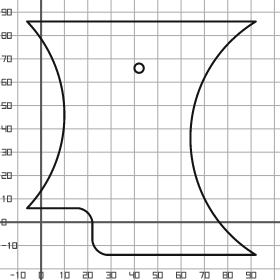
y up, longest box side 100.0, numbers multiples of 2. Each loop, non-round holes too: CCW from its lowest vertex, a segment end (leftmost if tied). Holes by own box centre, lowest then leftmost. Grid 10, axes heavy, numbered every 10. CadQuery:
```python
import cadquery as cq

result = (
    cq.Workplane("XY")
    .moveTo(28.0, -14.0)
    .lineTo(92.0, -14.0)
    .threePointArc((64.0, 36.0), (92.0, 86.0))
    .lineTo(-6.0, 86.0)
    .threePointArc((10.0, 46.0), (-6.0, 6.0))
    .lineTo(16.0, 6.0)
    .threePointArc((20.0, 4.0), (22.0, 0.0))
    .lineTo(22.0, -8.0)
    .threePointArc((24.0, -12.0), (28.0, -14.0))
    .close()
    .moveTo(42.0, 66.0)
    .circle(2.0)
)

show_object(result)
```